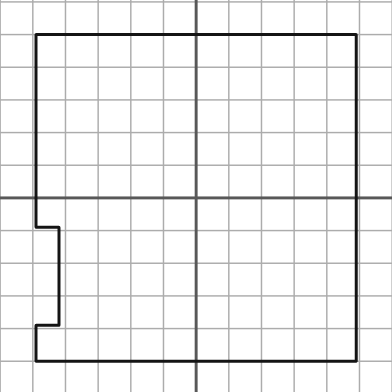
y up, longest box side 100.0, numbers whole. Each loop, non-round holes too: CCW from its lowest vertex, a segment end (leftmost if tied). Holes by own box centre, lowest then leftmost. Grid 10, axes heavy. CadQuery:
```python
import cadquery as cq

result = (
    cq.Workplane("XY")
    .moveTo(-49.0, -50.0)
    .lineTo(49.0, -50.0)
    .lineTo(49.0, 50.0)
    .lineTo(-49.0, 50.0)
    .lineTo(-49.0, -9.0)
    .lineTo(-42.0, -9.0)
    .lineTo(-42.0, -39.0)
    .lineTo(-49.0, -39.0)
    .close()
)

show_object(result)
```